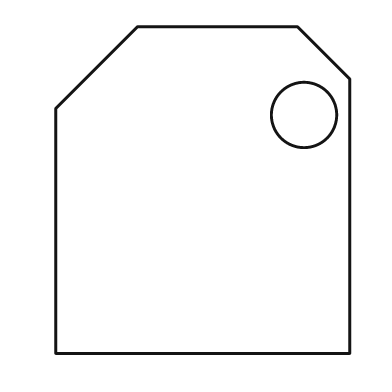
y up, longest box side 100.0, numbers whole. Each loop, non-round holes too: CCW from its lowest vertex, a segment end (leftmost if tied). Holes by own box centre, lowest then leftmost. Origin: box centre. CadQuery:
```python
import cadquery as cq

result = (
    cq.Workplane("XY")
    .moveTo(-45.0, -50.0)
    .lineTo(45.0, -50.0)
    .lineTo(45.0, 34.0)
    .lineTo(29.0, 50.0)
    .lineTo(-20.0, 50.0)
    .lineTo(-45.0, 25.0)
    .close()
    .moveTo(31.0, 23.0)
    .circle(10.0)
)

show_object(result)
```